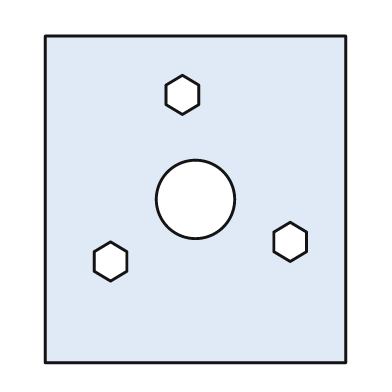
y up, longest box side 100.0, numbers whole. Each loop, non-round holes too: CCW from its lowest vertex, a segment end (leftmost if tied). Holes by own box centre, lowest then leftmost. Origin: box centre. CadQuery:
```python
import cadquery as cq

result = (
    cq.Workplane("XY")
    .moveTo(-46.0, -50.0)
    .lineTo(46.0, -50.0)
    .lineTo(46.0, 50.0)
    .lineTo(-46.0, 50.0)
    .close()
    .moveTo(-26.0, -25.0)
    .lineTo(-21.0, -22.0)
    .lineTo(-21.0, -16.0)
    .lineTo(-26.0, -13.0)
    .lineTo(-31.0, -16.0)
    .lineTo(-31.0, -22.0)
    .close()
    .moveTo(29.0, -19.0)
    .lineTo(34.0, -16.0)
    .lineTo(34.0, -10.0)
    .lineTo(29.0, -7.0)
    .lineTo(24.0, -10.0)
    .lineTo(24.0, -16.0)
    .close()
    .moveTo(0.0, 0.0)
    .circle(12.0)
    .moveTo(-4.0, 26.0)
    .lineTo(1.0, 29.0)
    .lineTo(1.0, 35.0)
    .lineTo(-4.0, 38.0)
    .lineTo(-9.0, 35.0)
    .lineTo(-9.0, 29.0)
    .close()
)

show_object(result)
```